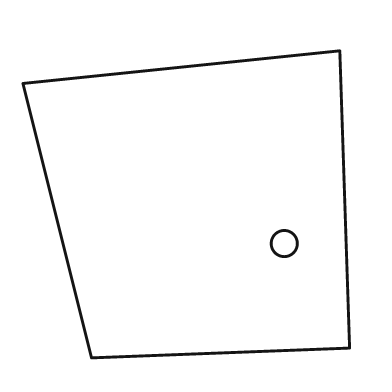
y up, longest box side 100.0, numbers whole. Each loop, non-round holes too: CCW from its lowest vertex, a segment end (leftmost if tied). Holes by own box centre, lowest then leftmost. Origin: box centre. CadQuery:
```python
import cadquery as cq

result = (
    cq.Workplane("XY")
    .moveTo(-29.0, -47.0)
    .lineTo(50.0, -44.0)
    .lineTo(47.0, 47.0)
    .lineTo(-50.0, 37.0)
    .close()
    .moveTo(30.0, -12.0)
    .circle(4.0)
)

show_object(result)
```